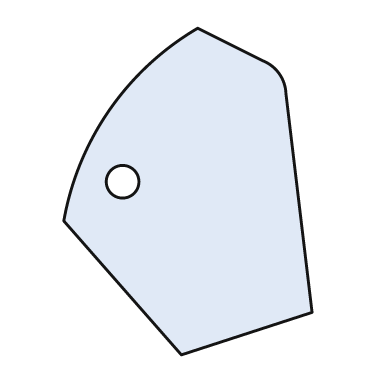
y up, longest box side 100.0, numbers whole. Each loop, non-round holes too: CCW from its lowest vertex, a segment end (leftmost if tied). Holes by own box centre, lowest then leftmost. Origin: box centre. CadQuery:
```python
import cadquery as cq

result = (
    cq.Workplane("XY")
    .moveTo(-2.0, -50.0)
    .lineTo(38.0, -37.0)
    .lineTo(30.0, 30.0)
    .threePointArc((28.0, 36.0), (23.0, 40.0))
    .lineTo(3.0, 50.0)
    .threePointArc((-24.0, 25.0), (-38.0, -9.0))
    .close()
    .moveTo(-20.0, 3.0)
    .circle(5.0)
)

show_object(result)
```